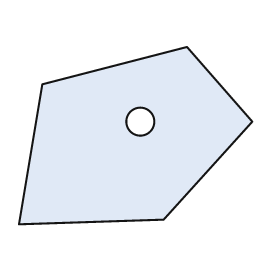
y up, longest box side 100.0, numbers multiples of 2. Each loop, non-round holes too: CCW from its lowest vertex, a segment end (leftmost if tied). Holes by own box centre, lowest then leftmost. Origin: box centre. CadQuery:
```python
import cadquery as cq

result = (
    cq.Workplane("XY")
    .moveTo(-50.0, -38.0)
    .lineTo(12.0, -36.0)
    .lineTo(50.0, 6.0)
    .lineTo(22.0, 38.0)
    .lineTo(-40.0, 22.0)
    .close()
    .moveTo(2.0, 6.0)
    .circle(6.0)
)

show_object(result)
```